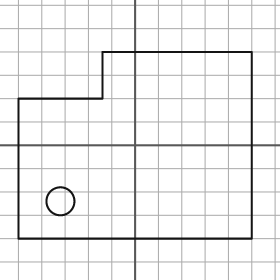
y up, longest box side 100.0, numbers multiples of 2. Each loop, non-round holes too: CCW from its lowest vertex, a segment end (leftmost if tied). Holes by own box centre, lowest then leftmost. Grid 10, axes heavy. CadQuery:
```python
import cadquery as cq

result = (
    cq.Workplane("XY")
    .moveTo(-50.0, -40.0)
    .lineTo(50.0, -40.0)
    .lineTo(50.0, 40.0)
    .lineTo(-14.0, 40.0)
    .lineTo(-14.0, 20.0)
    .lineTo(-50.0, 20.0)
    .close()
    .moveTo(-32.0, -24.0)
    .circle(6.0)
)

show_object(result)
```